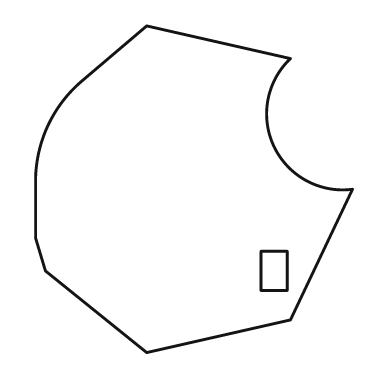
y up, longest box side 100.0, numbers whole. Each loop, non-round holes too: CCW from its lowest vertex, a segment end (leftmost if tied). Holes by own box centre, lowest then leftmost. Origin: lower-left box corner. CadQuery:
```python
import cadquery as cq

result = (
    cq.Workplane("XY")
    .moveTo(34.0, 0.0)
    .lineTo(78.0, 10.0)
    .lineTo(97.0, 50.0)
    .threePointArc((73.0, 63.0), (78.0, 90.0))
    .lineTo(34.0, 100.0)
    .lineTo(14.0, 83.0)
    .threePointArc((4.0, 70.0), (0.0, 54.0))
    .lineTo(0.0, 35.0)
    .lineTo(3.0, 25.0)
    .close()
    .moveTo(69.0, 19.0)
    .lineTo(77.0, 19.0)
    .lineTo(77.0, 31.0)
    .lineTo(69.0, 31.0)
    .close()
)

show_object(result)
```